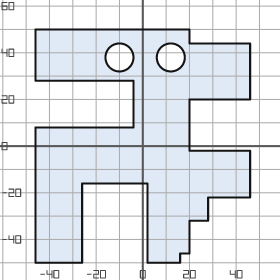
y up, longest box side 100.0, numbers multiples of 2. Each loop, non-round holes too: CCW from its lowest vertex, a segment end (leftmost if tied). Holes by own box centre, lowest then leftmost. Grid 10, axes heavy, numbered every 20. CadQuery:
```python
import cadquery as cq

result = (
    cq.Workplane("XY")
    .moveTo(-46.0, -50.0)
    .lineTo(-26.0, -50.0)
    .lineTo(-26.0, -16.0)
    .lineTo(2.0, -16.0)
    .lineTo(2.0, -50.0)
    .lineTo(16.0, -50.0)
    .lineTo(16.0, -46.0)
    .lineTo(20.0, -46.0)
    .lineTo(20.0, -32.0)
    .lineTo(28.0, -32.0)
    .lineTo(28.0, -22.0)
    .lineTo(46.0, -22.0)
    .lineTo(46.0, -2.0)
    .lineTo(20.0, -2.0)
    .lineTo(20.0, 20.0)
    .lineTo(46.0, 20.0)
    .lineTo(46.0, 44.0)
    .lineTo(20.0, 44.0)
    .lineTo(20.0, 50.0)
    .lineTo(-46.0, 50.0)
    .lineTo(-46.0, 28.0)
    .lineTo(-4.0, 28.0)
    .lineTo(-4.0, 8.0)
    .lineTo(-46.0, 8.0)
    .close()
    .moveTo(-10.0, 38.0)
    .circle(6.0)
    .moveTo(12.0, 38.0)
    .circle(6.0)
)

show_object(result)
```